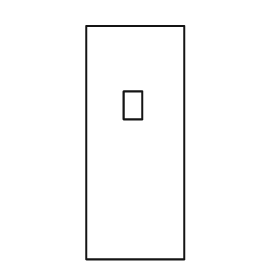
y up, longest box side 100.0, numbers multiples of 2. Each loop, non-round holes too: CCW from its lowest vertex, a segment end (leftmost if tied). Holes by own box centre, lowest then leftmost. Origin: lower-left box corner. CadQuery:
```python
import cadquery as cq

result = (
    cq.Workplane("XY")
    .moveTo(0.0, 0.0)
    .lineTo(42.0, 0.0)
    .lineTo(42.0, 100.0)
    .lineTo(0.0, 100.0)
    .close()
    .moveTo(16.0, 60.0)
    .lineTo(24.0, 60.0)
    .lineTo(24.0, 72.0)
    .lineTo(16.0, 72.0)
    .close()
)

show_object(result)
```